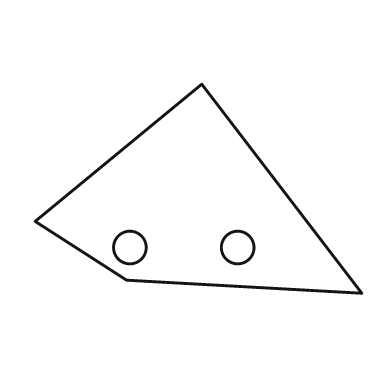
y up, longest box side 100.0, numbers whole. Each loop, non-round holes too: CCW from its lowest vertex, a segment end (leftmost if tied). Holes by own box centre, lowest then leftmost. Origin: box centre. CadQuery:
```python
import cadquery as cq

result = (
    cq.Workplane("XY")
    .moveTo(50.0, -32.0)
    .lineTo(1.0, 32.0)
    .lineTo(-50.0, -10.0)
    .lineTo(-22.0, -28.0)
    .close()
    .moveTo(-21.0, -18.0)
    .circle(5.0)
    .moveTo(12.0, -18.0)
    .circle(5.0)
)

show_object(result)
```